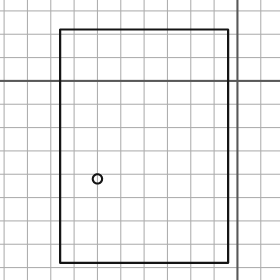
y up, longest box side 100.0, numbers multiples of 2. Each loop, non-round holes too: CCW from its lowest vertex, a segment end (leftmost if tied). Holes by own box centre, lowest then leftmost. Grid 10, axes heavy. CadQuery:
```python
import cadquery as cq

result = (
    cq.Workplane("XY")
    .moveTo(-76.0, -78.0)
    .lineTo(-4.0, -78.0)
    .lineTo(-4.0, 22.0)
    .lineTo(-76.0, 22.0)
    .close()
    .moveTo(-60.0, -42.0)
    .circle(2.0)
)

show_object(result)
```